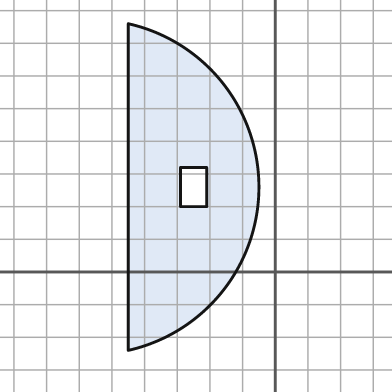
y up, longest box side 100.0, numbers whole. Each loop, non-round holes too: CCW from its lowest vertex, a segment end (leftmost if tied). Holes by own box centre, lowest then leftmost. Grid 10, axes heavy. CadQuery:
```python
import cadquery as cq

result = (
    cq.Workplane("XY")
    .moveTo(-45.0, -24.0)
    .threePointArc((-5.0, 26.0), (-45.0, 76.0))
    .close()
    .moveTo(-29.0, 20.0)
    .lineTo(-21.0, 20.0)
    .lineTo(-21.0, 32.0)
    .lineTo(-29.0, 32.0)
    .close()
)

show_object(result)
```